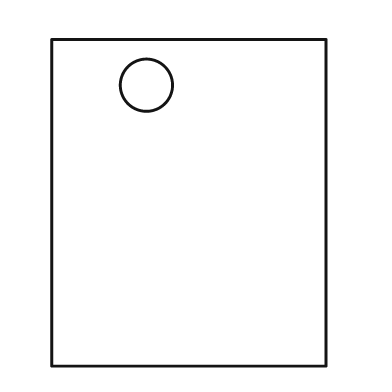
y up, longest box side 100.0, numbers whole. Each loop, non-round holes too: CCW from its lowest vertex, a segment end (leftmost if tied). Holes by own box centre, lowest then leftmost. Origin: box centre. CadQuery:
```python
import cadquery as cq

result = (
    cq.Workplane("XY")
    .moveTo(-42.0, -50.0)
    .lineTo(42.0, -50.0)
    .lineTo(42.0, 50.0)
    .lineTo(-42.0, 50.0)
    .close()
    .moveTo(-13.0, 36.0)
    .circle(8.0)
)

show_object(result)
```